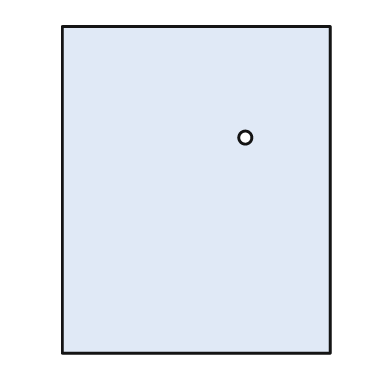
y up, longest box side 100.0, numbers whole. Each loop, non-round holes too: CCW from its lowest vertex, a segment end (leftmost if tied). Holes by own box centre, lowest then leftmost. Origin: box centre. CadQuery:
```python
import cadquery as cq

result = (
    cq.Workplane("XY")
    .moveTo(-41.0, -50.0)
    .lineTo(41.0, -50.0)
    .lineTo(41.0, 50.0)
    .lineTo(-41.0, 50.0)
    .close()
    .moveTo(15.0, 16.0)
    .circle(2.0)
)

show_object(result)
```